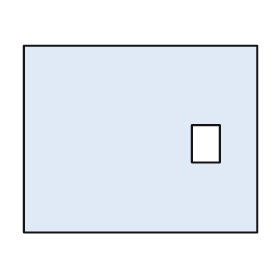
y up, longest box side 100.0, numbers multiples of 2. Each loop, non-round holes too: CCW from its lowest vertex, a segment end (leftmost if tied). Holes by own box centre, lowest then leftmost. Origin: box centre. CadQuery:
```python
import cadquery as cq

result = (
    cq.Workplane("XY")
    .moveTo(-50.0, -40.0)
    .lineTo(50.0, -40.0)
    .lineTo(50.0, 40.0)
    .lineTo(-50.0, 40.0)
    .close()
    .moveTo(22.0, -10.0)
    .lineTo(34.0, -10.0)
    .lineTo(34.0, 6.0)
    .lineTo(22.0, 6.0)
    .close()
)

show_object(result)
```